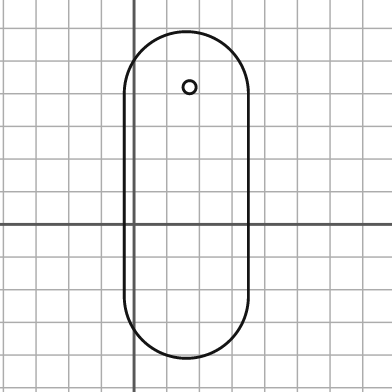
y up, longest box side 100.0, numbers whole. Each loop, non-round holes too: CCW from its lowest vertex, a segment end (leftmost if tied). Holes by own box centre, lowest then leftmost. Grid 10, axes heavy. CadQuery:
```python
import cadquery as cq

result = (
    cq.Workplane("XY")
    .moveTo(-3.0, -22.0)
    .threePointArc((16.0, -41.0), (35.0, -22.0))
    .lineTo(35.0, 40.0)
    .threePointArc((16.0, 59.0), (-3.0, 40.0))
    .close()
    .moveTo(17.0, 42.0)
    .circle(2.0)
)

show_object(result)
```